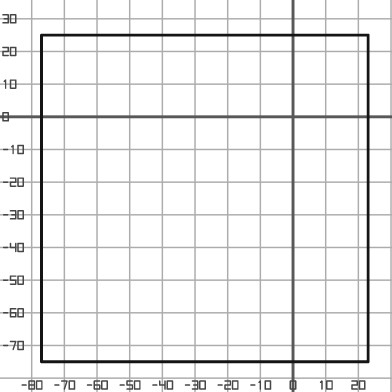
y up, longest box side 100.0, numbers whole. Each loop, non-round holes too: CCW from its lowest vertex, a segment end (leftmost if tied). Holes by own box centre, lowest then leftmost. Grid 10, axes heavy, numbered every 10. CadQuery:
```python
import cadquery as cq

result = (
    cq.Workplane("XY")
    .moveTo(-77.0, -75.0)
    .lineTo(23.0, -75.0)
    .lineTo(23.0, 25.0)
    .lineTo(-77.0, 25.0)
    .close()
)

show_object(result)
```